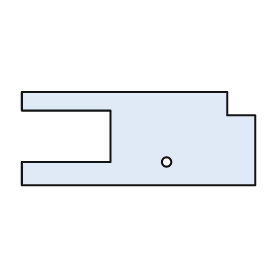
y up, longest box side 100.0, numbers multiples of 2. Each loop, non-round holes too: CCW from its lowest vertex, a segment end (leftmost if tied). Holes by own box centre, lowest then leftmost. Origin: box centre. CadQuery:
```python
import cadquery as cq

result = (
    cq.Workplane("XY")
    .moveTo(-50.0, -20.0)
    .lineTo(50.0, -20.0)
    .lineTo(50.0, 10.0)
    .lineTo(38.0, 10.0)
    .lineTo(38.0, 20.0)
    .lineTo(-50.0, 20.0)
    .lineTo(-50.0, 12.0)
    .lineTo(-12.0, 12.0)
    .lineTo(-12.0, -10.0)
    .lineTo(-50.0, -10.0)
    .close()
    .moveTo(12.0, -10.0)
    .circle(2.0)
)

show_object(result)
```